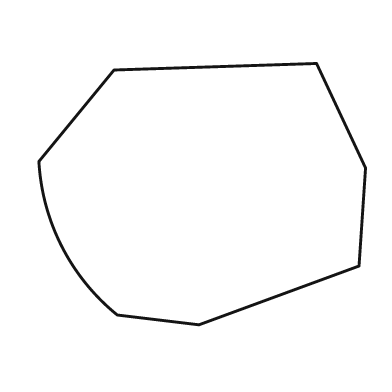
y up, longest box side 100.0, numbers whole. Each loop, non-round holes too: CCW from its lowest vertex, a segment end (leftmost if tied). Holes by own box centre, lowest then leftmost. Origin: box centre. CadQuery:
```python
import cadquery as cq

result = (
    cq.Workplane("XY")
    .moveTo(-1.0, -40.0)
    .lineTo(48.0, -22.0)
    .lineTo(50.0, 8.0)
    .lineTo(35.0, 40.0)
    .lineTo(-27.0, 38.0)
    .lineTo(-50.0, 10.0)
    .threePointArc((-43.0, -16.0), (-26.0, -37.0))
    .close()
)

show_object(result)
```